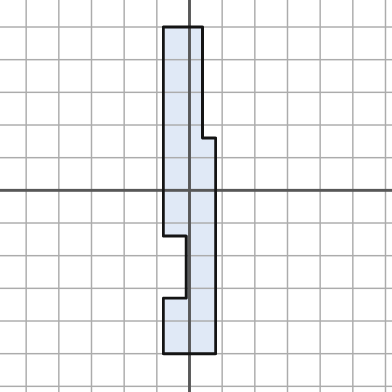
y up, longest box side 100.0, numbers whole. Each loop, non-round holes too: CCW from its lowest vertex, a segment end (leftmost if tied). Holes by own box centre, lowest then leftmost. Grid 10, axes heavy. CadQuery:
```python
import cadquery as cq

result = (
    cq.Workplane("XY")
    .moveTo(-8.0, -50.0)
    .lineTo(8.0, -50.0)
    .lineTo(8.0, 16.0)
    .lineTo(4.0, 16.0)
    .lineTo(4.0, 50.0)
    .lineTo(-8.0, 50.0)
    .lineTo(-8.0, -14.0)
    .lineTo(-1.0, -14.0)
    .lineTo(-1.0, -33.0)
    .lineTo(-8.0, -33.0)
    .close()
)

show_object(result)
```